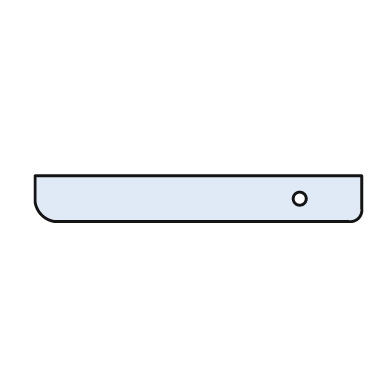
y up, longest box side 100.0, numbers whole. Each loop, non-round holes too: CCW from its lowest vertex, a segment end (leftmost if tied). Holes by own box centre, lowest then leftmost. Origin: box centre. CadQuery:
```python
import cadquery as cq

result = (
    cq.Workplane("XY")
    .moveTo(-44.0, -7.0)
    .lineTo(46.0, -7.0)
    .threePointArc((49.0, -6.0), (50.0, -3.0))
    .lineTo(50.0, 7.0)
    .lineTo(-50.0, 7.0)
    .lineTo(-50.0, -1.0)
    .threePointArc((-48.0, -5.0), (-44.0, -7.0))
    .close()
    .moveTo(31.0, 0.0)
    .circle(2.0)
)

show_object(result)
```